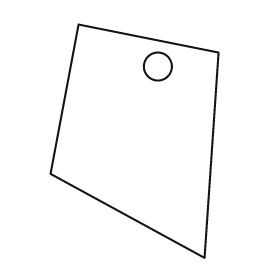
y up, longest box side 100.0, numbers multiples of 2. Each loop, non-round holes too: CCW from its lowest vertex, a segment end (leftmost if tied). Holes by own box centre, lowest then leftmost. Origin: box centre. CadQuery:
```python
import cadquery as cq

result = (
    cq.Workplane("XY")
    .moveTo(30.0, -50.0)
    .lineTo(36.0, 38.0)
    .lineTo(-24.0, 50.0)
    .lineTo(-36.0, -14.0)
    .close()
    .moveTo(10.0, 32.0)
    .circle(6.0)
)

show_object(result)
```